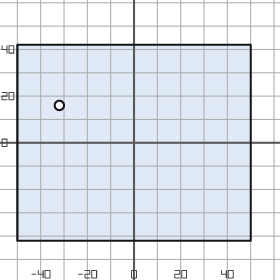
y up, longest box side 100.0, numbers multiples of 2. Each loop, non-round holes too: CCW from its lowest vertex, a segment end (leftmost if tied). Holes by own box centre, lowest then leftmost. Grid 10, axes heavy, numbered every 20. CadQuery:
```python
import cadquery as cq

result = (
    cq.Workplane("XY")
    .moveTo(-50.0, -42.0)
    .lineTo(50.0, -42.0)
    .lineTo(50.0, 42.0)
    .lineTo(-50.0, 42.0)
    .close()
    .moveTo(-32.0, 16.0)
    .circle(2.0)
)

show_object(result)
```